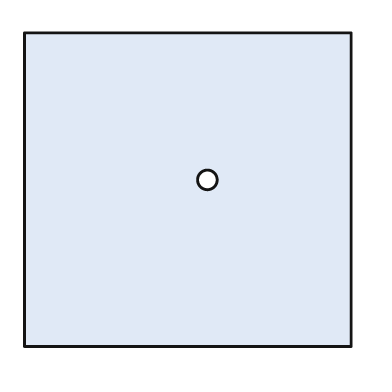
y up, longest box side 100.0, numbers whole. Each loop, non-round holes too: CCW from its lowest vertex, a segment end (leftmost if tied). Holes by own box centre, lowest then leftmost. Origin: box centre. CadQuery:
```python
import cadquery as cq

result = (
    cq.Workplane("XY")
    .moveTo(-50.0, -48.0)
    .lineTo(50.0, -48.0)
    .lineTo(50.0, 48.0)
    .lineTo(-50.0, 48.0)
    .close()
    .moveTo(6.0, 3.0)
    .circle(3.0)
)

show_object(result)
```